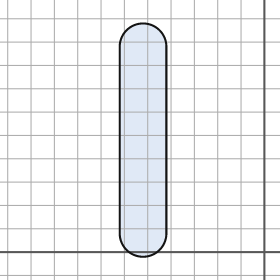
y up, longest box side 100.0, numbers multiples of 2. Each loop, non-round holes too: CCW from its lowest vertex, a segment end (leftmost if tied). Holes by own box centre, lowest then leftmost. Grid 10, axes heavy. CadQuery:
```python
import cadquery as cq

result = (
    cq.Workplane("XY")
    .moveTo(-62.0, 8.0)
    .threePointArc((-52.0, -2.0), (-42.0, 8.0))
    .lineTo(-42.0, 88.0)
    .threePointArc((-52.0, 98.0), (-62.0, 88.0))
    .close()
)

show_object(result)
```